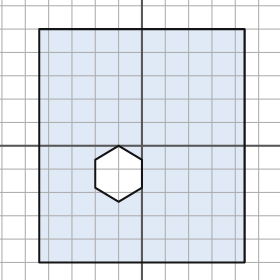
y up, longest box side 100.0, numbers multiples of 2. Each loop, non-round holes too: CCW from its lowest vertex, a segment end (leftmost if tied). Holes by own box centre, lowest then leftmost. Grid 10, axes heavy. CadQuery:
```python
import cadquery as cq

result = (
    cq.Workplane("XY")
    .moveTo(-44.0, -50.0)
    .lineTo(44.0, -50.0)
    .lineTo(44.0, 50.0)
    .lineTo(-44.0, 50.0)
    .close()
    .moveTo(-10.0, -24.0)
    .lineTo(0.0, -18.0)
    .lineTo(0.0, -6.0)
    .lineTo(-10.0, 0.0)
    .lineTo(-20.0, -6.0)
    .lineTo(-20.0, -18.0)
    .close()
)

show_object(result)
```